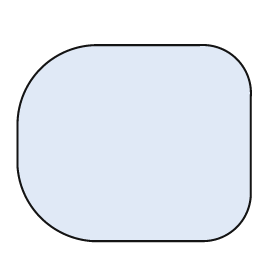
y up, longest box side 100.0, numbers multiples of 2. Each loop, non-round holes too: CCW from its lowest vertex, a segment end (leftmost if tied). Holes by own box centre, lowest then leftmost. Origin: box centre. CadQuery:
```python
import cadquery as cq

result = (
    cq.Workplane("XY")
    .moveTo(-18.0, -42.0)
    .lineTo(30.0, -42.0)
    .threePointArc((44.0, -36.0), (50.0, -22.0))
    .lineTo(50.0, 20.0)
    .threePointArc((44.0, 36.0), (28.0, 42.0))
    .lineTo(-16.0, 42.0)
    .threePointArc((-40.0, 32.0), (-50.0, 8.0))
    .lineTo(-50.0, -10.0)
    .threePointArc((-40.0, -32.0), (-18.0, -42.0))
    .close()
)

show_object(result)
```